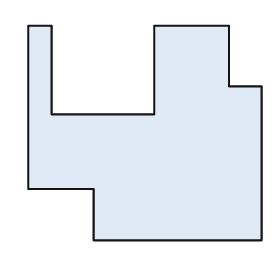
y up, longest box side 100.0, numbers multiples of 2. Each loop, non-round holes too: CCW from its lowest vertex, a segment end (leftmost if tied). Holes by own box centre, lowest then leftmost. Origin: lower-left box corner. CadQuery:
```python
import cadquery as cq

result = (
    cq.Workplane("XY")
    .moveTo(28.0, 0.0)
    .lineTo(100.0, 0.0)
    .lineTo(100.0, 66.0)
    .lineTo(86.0, 66.0)
    .lineTo(86.0, 92.0)
    .lineTo(54.0, 92.0)
    .lineTo(54.0, 54.0)
    .lineTo(10.0, 54.0)
    .lineTo(10.0, 92.0)
    .lineTo(0.0, 92.0)
    .lineTo(0.0, 22.0)
    .lineTo(28.0, 22.0)
    .close()
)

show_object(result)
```